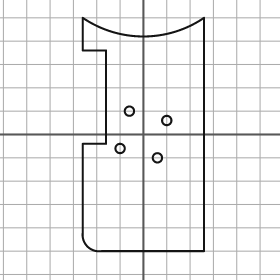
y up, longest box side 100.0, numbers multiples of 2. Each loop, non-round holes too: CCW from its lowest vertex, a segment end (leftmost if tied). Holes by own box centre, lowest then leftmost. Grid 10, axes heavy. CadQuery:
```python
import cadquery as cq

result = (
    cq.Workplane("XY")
    .moveTo(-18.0, -50.0)
    .lineTo(26.0, -50.0)
    .lineTo(26.0, 50.0)
    .threePointArc((0.0, 42.0), (-26.0, 50.0))
    .lineTo(-26.0, 36.0)
    .lineTo(-16.0, 36.0)
    .lineTo(-16.0, -4.0)
    .lineTo(-26.0, -4.0)
    .lineTo(-26.0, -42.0)
    .threePointArc((-24.0, -48.0), (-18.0, -50.0))
    .close()
    .moveTo(6.0, -10.0)
    .circle(2.0)
    .moveTo(-10.0, -6.0)
    .circle(2.0)
    .moveTo(10.0, 6.0)
    .circle(2.0)
    .moveTo(-6.0, 10.0)
    .circle(2.0)
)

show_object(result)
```